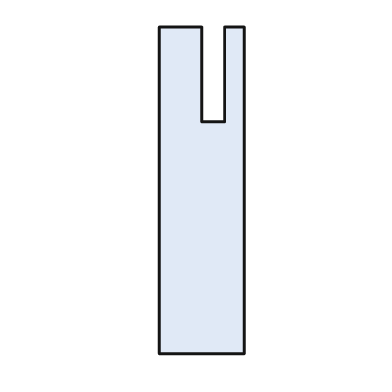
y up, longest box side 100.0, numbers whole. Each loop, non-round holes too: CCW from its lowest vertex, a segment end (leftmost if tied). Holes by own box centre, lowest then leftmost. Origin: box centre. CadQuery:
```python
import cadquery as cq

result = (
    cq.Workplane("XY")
    .moveTo(-13.0, -50.0)
    .lineTo(13.0, -50.0)
    .lineTo(13.0, 50.0)
    .lineTo(7.0, 50.0)
    .lineTo(7.0, 21.0)
    .lineTo(0.0, 21.0)
    .lineTo(0.0, 50.0)
    .lineTo(-13.0, 50.0)
    .close()
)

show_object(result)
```